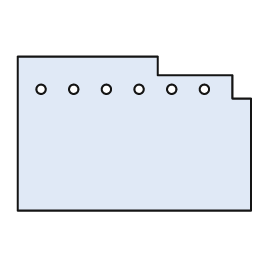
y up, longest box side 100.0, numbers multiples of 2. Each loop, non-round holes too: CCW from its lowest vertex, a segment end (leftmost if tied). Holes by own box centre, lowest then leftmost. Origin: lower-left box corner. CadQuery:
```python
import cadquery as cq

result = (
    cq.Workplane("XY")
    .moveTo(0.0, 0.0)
    .lineTo(100.0, 0.0)
    .lineTo(100.0, 48.0)
    .lineTo(92.0, 48.0)
    .lineTo(92.0, 58.0)
    .lineTo(60.0, 58.0)
    .lineTo(60.0, 66.0)
    .lineTo(0.0, 66.0)
    .close()
    .moveTo(10.0, 52.0)
    .circle(2.0)
    .moveTo(24.0, 52.0)
    .circle(2.0)
    .moveTo(38.0, 52.0)
    .circle(2.0)
    .moveTo(52.0, 52.0)
    .circle(2.0)
    .moveTo(66.0, 52.0)
    .circle(2.0)
    .moveTo(80.0, 52.0)
    .circle(2.0)
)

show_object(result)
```